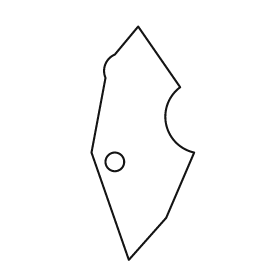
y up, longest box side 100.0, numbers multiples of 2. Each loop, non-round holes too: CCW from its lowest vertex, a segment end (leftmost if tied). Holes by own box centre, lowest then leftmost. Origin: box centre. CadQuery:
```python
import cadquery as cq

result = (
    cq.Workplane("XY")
    .moveTo(-6.0, -50.0)
    .lineTo(10.0, -32.0)
    .lineTo(22.0, -4.0)
    .threePointArc((10.0, 8.0), (16.0, 24.0))
    .lineTo(-2.0, 50.0)
    .lineTo(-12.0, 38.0)
    .threePointArc((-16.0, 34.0), (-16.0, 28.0))
    .lineTo(-22.0, -4.0)
    .close()
    .moveTo(-12.0, -8.0)
    .circle(4.0)
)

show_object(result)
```